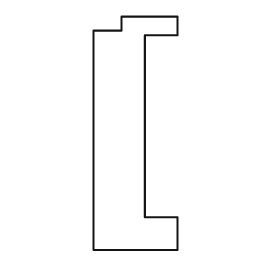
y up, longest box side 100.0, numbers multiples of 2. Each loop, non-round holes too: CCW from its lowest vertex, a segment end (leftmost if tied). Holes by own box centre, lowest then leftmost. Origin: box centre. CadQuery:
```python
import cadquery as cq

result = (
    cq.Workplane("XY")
    .moveTo(-18.0, -50.0)
    .lineTo(18.0, -50.0)
    .lineTo(18.0, -36.0)
    .lineTo(4.0, -36.0)
    .lineTo(4.0, 42.0)
    .lineTo(18.0, 42.0)
    .lineTo(18.0, 50.0)
    .lineTo(-6.0, 50.0)
    .lineTo(-6.0, 44.0)
    .lineTo(-18.0, 44.0)
    .close()
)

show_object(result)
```